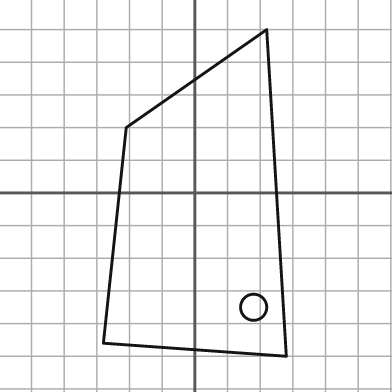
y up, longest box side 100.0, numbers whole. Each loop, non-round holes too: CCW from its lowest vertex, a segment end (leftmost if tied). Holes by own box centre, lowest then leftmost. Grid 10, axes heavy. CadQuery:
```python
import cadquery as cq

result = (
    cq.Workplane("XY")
    .moveTo(28.0, -50.0)
    .lineTo(22.0, 50.0)
    .lineTo(-21.0, 20.0)
    .lineTo(-28.0, -46.0)
    .close()
    .moveTo(18.0, -35.0)
    .circle(4.0)
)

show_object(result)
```